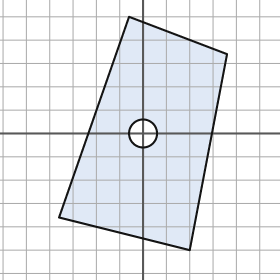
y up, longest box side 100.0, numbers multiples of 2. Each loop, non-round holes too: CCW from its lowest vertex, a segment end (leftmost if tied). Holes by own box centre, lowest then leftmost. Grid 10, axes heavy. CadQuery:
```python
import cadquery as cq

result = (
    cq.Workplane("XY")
    .moveTo(20.0, -50.0)
    .lineTo(36.0, 34.0)
    .lineTo(-6.0, 50.0)
    .lineTo(-36.0, -36.0)
    .close()
    .moveTo(0.0, 0.0)
    .circle(6.0)
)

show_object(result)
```